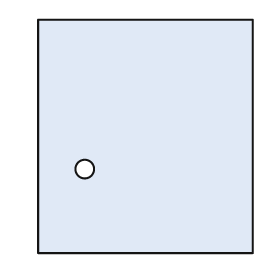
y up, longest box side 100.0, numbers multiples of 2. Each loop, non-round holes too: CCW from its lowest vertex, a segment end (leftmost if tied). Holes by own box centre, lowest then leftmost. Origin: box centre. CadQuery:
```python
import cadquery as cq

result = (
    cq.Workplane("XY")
    .moveTo(-46.0, -50.0)
    .lineTo(46.0, -50.0)
    .lineTo(46.0, 50.0)
    .lineTo(-46.0, 50.0)
    .close()
    .moveTo(-26.0, -14.0)
    .circle(4.0)
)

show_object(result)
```